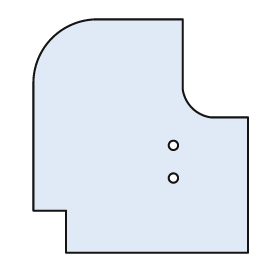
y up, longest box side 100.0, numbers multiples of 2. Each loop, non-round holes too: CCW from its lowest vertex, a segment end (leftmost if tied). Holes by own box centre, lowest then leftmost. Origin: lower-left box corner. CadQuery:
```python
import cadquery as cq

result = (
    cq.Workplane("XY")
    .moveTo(14.0, 0.0)
    .lineTo(92.0, 0.0)
    .lineTo(92.0, 58.0)
    .lineTo(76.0, 58.0)
    .threePointArc((68.0, 62.0), (64.0, 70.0))
    .lineTo(64.0, 100.0)
    .lineTo(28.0, 100.0)
    .threePointArc((8.0, 92.0), (0.0, 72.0))
    .lineTo(0.0, 18.0)
    .lineTo(14.0, 18.0)
    .close()
    .moveTo(60.0, 32.0)
    .circle(2.0)
    .moveTo(60.0, 46.0)
    .circle(2.0)
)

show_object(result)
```